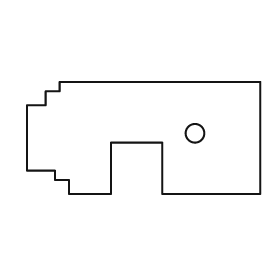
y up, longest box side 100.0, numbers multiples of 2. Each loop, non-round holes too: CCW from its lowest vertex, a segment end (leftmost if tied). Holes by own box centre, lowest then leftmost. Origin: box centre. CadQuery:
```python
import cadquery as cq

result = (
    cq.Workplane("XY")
    .moveTo(-32.0, -24.0)
    .lineTo(-14.0, -24.0)
    .lineTo(-14.0, -2.0)
    .lineTo(8.0, -2.0)
    .lineTo(8.0, -24.0)
    .lineTo(50.0, -24.0)
    .lineTo(50.0, 24.0)
    .lineTo(-36.0, 24.0)
    .lineTo(-36.0, 20.0)
    .lineTo(-42.0, 20.0)
    .lineTo(-42.0, 14.0)
    .lineTo(-50.0, 14.0)
    .lineTo(-50.0, -14.0)
    .lineTo(-38.0, -14.0)
    .lineTo(-38.0, -18.0)
    .lineTo(-32.0, -18.0)
    .close()
    .moveTo(22.0, 2.0)
    .circle(4.0)
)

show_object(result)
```